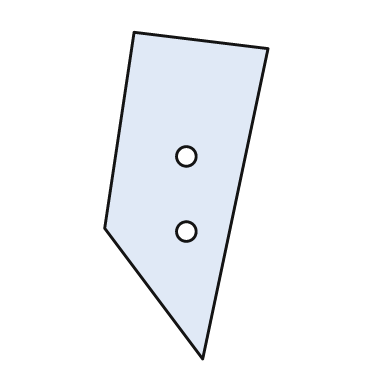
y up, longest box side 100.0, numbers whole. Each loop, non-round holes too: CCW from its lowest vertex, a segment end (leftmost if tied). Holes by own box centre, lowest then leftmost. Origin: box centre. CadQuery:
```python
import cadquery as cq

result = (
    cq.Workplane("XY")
    .moveTo(5.0, -50.0)
    .lineTo(25.0, 45.0)
    .lineTo(-16.0, 50.0)
    .lineTo(-25.0, -10.0)
    .close()
    .moveTo(0.0, -11.0)
    .circle(3.0)
    .moveTo(0.0, 12.0)
    .circle(3.0)
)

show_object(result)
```